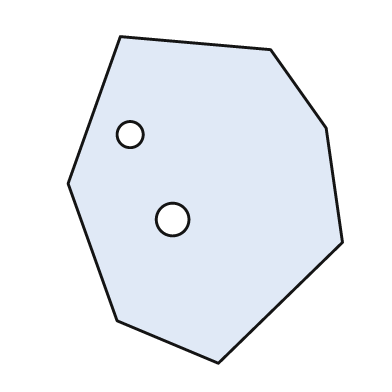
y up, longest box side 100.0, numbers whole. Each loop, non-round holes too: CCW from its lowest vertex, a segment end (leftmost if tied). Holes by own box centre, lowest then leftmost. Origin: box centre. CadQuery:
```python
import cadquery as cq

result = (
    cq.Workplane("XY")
    .moveTo(4.0, -50.0)
    .lineTo(42.0, -13.0)
    .lineTo(37.0, 22.0)
    .lineTo(20.0, 46.0)
    .lineTo(-26.0, 50.0)
    .lineTo(-42.0, 5.0)
    .lineTo(-27.0, -37.0)
    .close()
    .moveTo(-10.0, -6.0)
    .circle(5.0)
    .moveTo(-23.0, 20.0)
    .circle(4.0)
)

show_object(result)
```